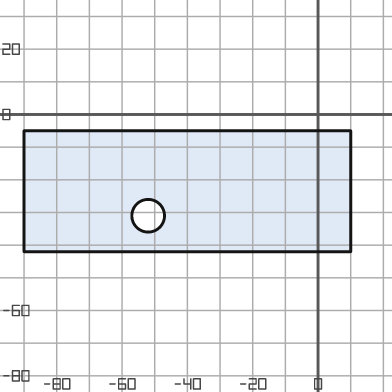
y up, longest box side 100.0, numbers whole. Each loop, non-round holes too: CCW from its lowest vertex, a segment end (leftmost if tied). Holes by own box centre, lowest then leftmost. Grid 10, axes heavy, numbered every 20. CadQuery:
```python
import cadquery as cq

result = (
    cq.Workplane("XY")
    .moveTo(-90.0, -42.0)
    .lineTo(10.0, -42.0)
    .lineTo(10.0, -5.0)
    .lineTo(-90.0, -5.0)
    .close()
    .moveTo(-52.0, -31.0)
    .circle(5.0)
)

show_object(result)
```